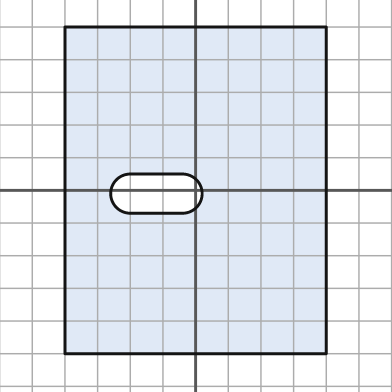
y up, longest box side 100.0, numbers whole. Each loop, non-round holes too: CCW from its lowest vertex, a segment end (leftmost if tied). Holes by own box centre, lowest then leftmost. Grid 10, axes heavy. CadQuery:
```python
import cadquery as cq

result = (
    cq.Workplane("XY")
    .moveTo(-40.0, -50.0)
    .lineTo(40.0, -50.0)
    .lineTo(40.0, 50.0)
    .lineTo(-40.0, 50.0)
    .close()
    .moveTo(-20.0, -7.0)
    .lineTo(-4.0, -7.0)
    .threePointArc((2.0, -1.0), (-4.0, 5.0))
    .lineTo(-20.0, 5.0)
    .threePointArc((-26.0, -1.0), (-20.0, -7.0))
    .close()
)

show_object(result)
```